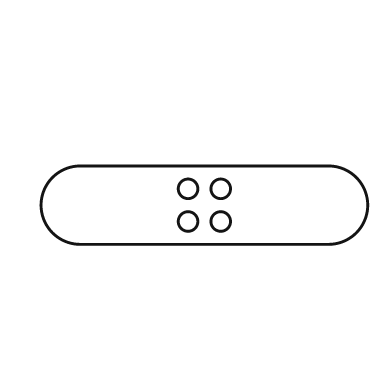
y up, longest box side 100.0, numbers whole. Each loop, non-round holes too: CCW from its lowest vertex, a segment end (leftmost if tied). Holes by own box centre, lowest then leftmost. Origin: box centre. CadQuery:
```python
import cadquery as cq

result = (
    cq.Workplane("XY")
    .moveTo(-38.0, -12.0)
    .lineTo(38.0, -12.0)
    .threePointArc((50.0, 0.0), (38.0, 12.0))
    .lineTo(-38.0, 12.0)
    .threePointArc((-50.0, 0.0), (-38.0, -12.0))
    .close()
    .moveTo(-5.0, -5.0)
    .circle(3.0)
    .moveTo(5.0, -5.0)
    .circle(3.0)
    .moveTo(-5.0, 5.0)
    .circle(3.0)
    .moveTo(5.0, 5.0)
    .circle(3.0)
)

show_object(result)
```